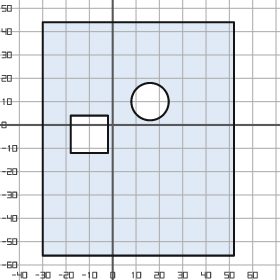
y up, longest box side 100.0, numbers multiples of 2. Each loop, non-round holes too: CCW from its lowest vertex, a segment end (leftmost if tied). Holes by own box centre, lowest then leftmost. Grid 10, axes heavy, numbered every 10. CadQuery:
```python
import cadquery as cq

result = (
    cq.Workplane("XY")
    .moveTo(-30.0, -56.0)
    .lineTo(52.0, -56.0)
    .lineTo(52.0, 44.0)
    .lineTo(-30.0, 44.0)
    .close()
    .moveTo(-18.0, -12.0)
    .lineTo(-2.0, -12.0)
    .lineTo(-2.0, 4.0)
    .lineTo(-18.0, 4.0)
    .close()
    .moveTo(16.0, 10.0)
    .circle(8.0)
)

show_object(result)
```